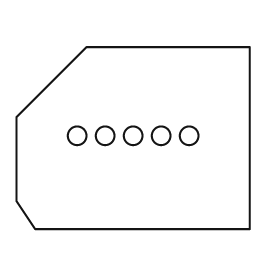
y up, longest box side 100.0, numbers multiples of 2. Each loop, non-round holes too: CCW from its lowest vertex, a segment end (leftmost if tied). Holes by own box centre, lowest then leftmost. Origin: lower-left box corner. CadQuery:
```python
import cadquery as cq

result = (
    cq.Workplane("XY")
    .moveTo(8.0, 0.0)
    .lineTo(100.0, 0.0)
    .lineTo(100.0, 78.0)
    .lineTo(30.0, 78.0)
    .lineTo(0.0, 48.0)
    .lineTo(0.0, 12.0)
    .close()
    .moveTo(26.0, 40.0)
    .circle(4.0)
    .moveTo(38.0, 40.0)
    .circle(4.0)
    .moveTo(50.0, 40.0)
    .circle(4.0)
    .moveTo(62.0, 40.0)
    .circle(4.0)
    .moveTo(74.0, 40.0)
    .circle(4.0)
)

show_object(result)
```